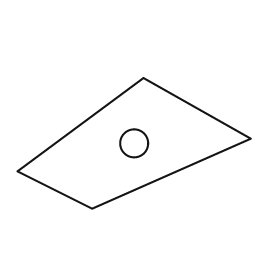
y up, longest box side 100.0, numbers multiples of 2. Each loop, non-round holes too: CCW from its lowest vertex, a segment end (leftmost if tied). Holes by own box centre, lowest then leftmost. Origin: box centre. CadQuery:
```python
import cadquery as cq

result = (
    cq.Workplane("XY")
    .moveTo(-18.0, -28.0)
    .lineTo(50.0, 2.0)
    .lineTo(4.0, 28.0)
    .lineTo(-50.0, -12.0)
    .close()
    .moveTo(0.0, 0.0)
    .circle(6.0)
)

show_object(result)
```